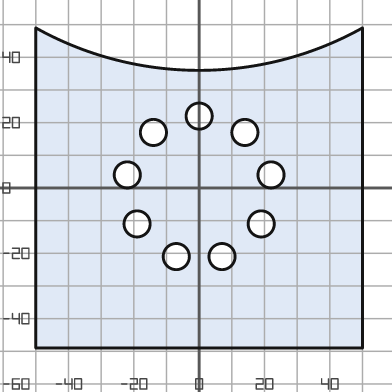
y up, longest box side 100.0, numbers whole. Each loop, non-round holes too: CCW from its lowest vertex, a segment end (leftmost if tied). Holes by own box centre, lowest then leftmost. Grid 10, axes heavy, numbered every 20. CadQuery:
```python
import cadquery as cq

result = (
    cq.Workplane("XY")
    .moveTo(-50.0, -49.0)
    .lineTo(50.0, -49.0)
    .lineTo(50.0, 49.0)
    .threePointArc((0.0, 36.0), (-50.0, 49.0))
    .close()
    .moveTo(-7.0, -21.0)
    .circle(4.0)
    .moveTo(7.0, -21.0)
    .circle(4.0)
    .moveTo(-19.0, -11.0)
    .circle(4.0)
    .moveTo(19.0, -11.0)
    .circle(4.0)
    .moveTo(-22.0, 4.0)
    .circle(4.0)
    .moveTo(22.0, 4.0)
    .circle(4.0)
    .moveTo(-14.0, 17.0)
    .circle(4.0)
    .moveTo(14.0, 17.0)
    .circle(4.0)
    .moveTo(0.0, 22.0)
    .circle(4.0)
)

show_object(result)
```